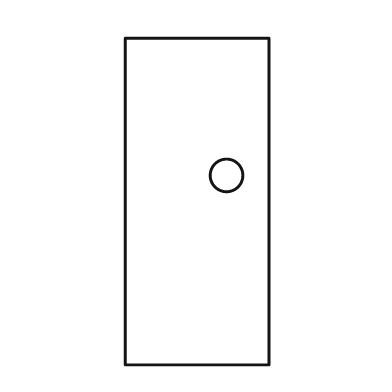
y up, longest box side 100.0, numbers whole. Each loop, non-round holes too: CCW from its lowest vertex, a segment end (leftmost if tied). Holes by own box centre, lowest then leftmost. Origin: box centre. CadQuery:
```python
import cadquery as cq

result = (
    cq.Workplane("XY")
    .moveTo(-22.0, -50.0)
    .lineTo(22.0, -50.0)
    .lineTo(22.0, 50.0)
    .lineTo(-22.0, 50.0)
    .close()
    .moveTo(9.0, 8.0)
    .circle(5.0)
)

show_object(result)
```